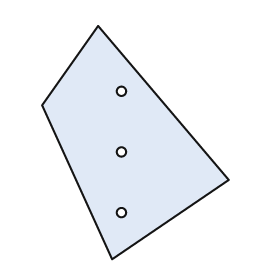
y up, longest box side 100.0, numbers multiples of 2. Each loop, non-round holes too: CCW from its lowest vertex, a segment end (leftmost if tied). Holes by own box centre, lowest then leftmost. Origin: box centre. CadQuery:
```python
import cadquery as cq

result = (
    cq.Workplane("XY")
    .moveTo(-10.0, -50.0)
    .lineTo(40.0, -16.0)
    .lineTo(-16.0, 50.0)
    .lineTo(-40.0, 16.0)
    .close()
    .moveTo(-6.0, -30.0)
    .circle(2.0)
    .moveTo(-6.0, -4.0)
    .circle(2.0)
    .moveTo(-6.0, 22.0)
    .circle(2.0)
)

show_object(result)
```